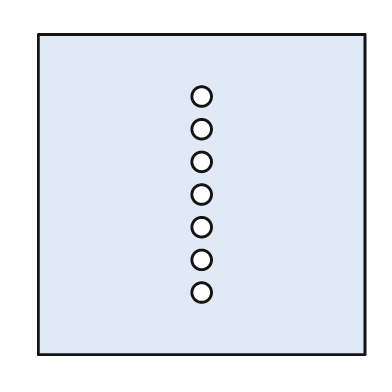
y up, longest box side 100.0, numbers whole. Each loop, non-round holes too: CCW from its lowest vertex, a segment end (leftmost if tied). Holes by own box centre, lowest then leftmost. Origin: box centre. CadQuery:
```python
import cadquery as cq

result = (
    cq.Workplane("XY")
    .moveTo(-50.0, -49.0)
    .lineTo(50.0, -49.0)
    .lineTo(50.0, 49.0)
    .lineTo(-50.0, 49.0)
    .close()
    .moveTo(0.0, -30.0)
    .circle(3.0)
    .moveTo(0.0, -20.0)
    .circle(3.0)
    .moveTo(0.0, -10.0)
    .circle(3.0)
    .moveTo(0.0, 0.0)
    .circle(3.0)
    .moveTo(0.0, 10.0)
    .circle(3.0)
    .moveTo(0.0, 20.0)
    .circle(3.0)
    .moveTo(0.0, 30.0)
    .circle(3.0)
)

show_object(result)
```